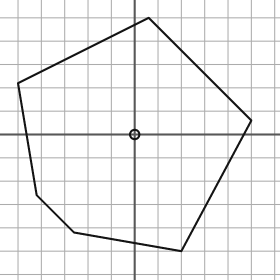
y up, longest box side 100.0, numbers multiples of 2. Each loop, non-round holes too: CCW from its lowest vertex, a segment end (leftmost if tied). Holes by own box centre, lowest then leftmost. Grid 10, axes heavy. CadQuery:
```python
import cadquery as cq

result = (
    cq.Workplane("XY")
    .moveTo(20.0, -50.0)
    .lineTo(50.0, 6.0)
    .lineTo(6.0, 50.0)
    .lineTo(-50.0, 22.0)
    .lineTo(-42.0, -26.0)
    .lineTo(-26.0, -42.0)
    .close()
    .moveTo(0.0, 0.0)
    .circle(2.0)
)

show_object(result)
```